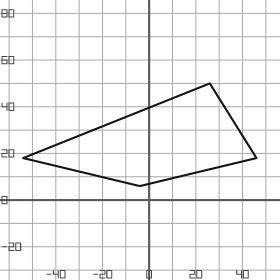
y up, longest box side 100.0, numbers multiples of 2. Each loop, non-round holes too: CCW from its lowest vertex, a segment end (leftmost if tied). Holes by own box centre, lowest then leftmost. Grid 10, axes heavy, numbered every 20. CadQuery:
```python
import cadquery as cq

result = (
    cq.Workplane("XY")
    .moveTo(-4.0, 6.0)
    .lineTo(46.0, 18.0)
    .lineTo(26.0, 50.0)
    .lineTo(-54.0, 18.0)
    .close()
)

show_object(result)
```